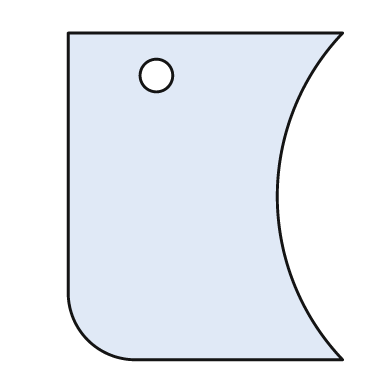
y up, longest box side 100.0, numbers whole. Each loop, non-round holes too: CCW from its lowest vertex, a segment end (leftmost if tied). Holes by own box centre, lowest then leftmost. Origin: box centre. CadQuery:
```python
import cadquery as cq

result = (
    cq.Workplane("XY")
    .moveTo(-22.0, -50.0)
    .lineTo(42.0, -50.0)
    .threePointArc((22.0, 0.0), (42.0, 50.0))
    .lineTo(-42.0, 50.0)
    .lineTo(-42.0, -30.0)
    .threePointArc((-36.0, -44.0), (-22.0, -50.0))
    .close()
    .moveTo(-15.0, 37.0)
    .circle(5.0)
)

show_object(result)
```